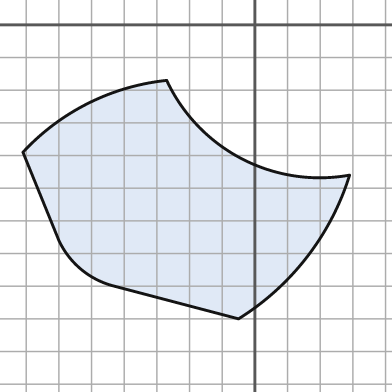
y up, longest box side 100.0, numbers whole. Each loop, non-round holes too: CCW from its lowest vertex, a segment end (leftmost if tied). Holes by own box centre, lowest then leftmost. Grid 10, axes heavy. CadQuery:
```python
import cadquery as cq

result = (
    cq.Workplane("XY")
    .moveTo(-5.0, -90.0)
    .threePointArc((16.0, -71.0), (29.0, -46.0))
    .threePointArc((-4.0, -41.0), (-27.0, -17.0))
    .threePointArc((-51.0, -24.0), (-71.0, -39.0))
    .lineTo(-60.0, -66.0)
    .threePointArc((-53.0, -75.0), (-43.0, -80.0))
    .close()
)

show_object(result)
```